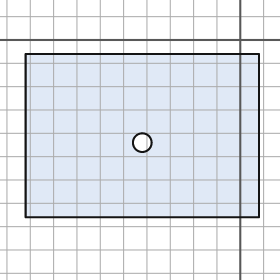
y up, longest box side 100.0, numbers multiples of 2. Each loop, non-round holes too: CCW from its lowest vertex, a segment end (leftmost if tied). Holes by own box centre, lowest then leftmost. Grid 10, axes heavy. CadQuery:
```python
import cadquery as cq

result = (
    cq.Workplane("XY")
    .moveTo(-92.0, -76.0)
    .lineTo(8.0, -76.0)
    .lineTo(8.0, -6.0)
    .lineTo(-92.0, -6.0)
    .close()
    .moveTo(-42.0, -44.0)
    .circle(4.0)
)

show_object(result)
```